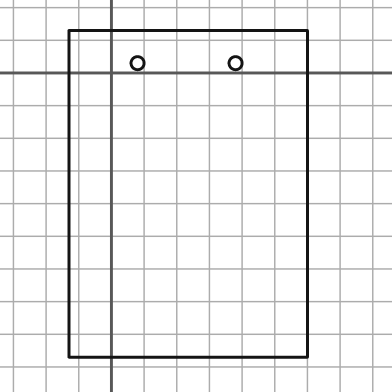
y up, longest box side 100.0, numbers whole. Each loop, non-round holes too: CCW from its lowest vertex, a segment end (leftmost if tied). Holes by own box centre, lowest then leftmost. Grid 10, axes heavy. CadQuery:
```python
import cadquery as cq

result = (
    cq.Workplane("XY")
    .moveTo(-13.0, -87.0)
    .lineTo(60.0, -87.0)
    .lineTo(60.0, 13.0)
    .lineTo(-13.0, 13.0)
    .close()
    .moveTo(8.0, 3.0)
    .circle(2.0)
    .moveTo(38.0, 3.0)
    .circle(2.0)
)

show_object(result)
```